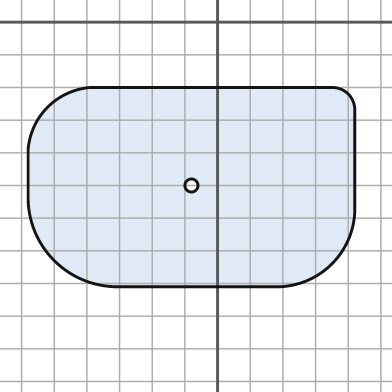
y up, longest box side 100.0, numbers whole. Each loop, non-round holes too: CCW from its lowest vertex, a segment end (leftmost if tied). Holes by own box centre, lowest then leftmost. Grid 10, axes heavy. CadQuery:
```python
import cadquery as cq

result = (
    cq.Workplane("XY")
    .moveTo(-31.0, -81.0)
    .lineTo(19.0, -81.0)
    .threePointArc((35.0, -74.0), (42.0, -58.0))
    .lineTo(42.0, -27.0)
    .threePointArc((40.0, -22.0), (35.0, -20.0))
    .lineTo(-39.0, -20.0)
    .threePointArc((-52.0, -26.0), (-58.0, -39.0))
    .lineTo(-58.0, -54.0)
    .threePointArc((-50.0, -73.0), (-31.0, -81.0))
    .close()
    .moveTo(-8.0, -50.0)
    .circle(2.0)
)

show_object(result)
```